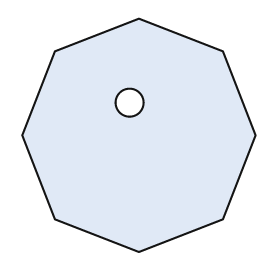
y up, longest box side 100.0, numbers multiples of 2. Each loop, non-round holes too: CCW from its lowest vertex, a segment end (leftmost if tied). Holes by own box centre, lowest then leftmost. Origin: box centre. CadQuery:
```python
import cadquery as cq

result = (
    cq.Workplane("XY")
    .moveTo(0.0, -50.0)
    .lineTo(36.0, -36.0)
    .lineTo(50.0, 0.0)
    .lineTo(36.0, 36.0)
    .lineTo(0.0, 50.0)
    .lineTo(-36.0, 36.0)
    .lineTo(-50.0, 0.0)
    .lineTo(-36.0, -36.0)
    .close()
    .moveTo(-4.0, 14.0)
    .circle(6.0)
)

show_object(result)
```